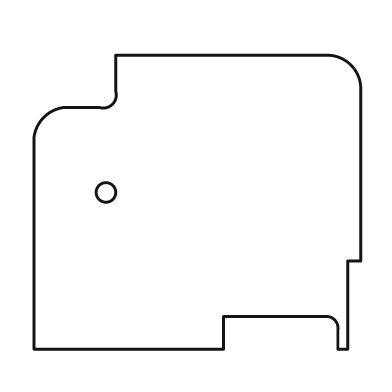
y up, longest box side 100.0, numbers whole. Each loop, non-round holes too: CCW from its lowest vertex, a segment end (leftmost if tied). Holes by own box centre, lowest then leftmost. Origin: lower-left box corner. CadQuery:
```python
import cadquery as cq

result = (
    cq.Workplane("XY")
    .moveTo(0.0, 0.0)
    .lineTo(58.0, 0.0)
    .lineTo(58.0, 10.0)
    .lineTo(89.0, 10.0)
    .threePointArc((92.0, 9.0), (93.0, 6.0))
    .lineTo(93.0, 0.0)
    .lineTo(96.0, 0.0)
    .lineTo(96.0, 27.0)
    .lineTo(100.0, 27.0)
    .lineTo(100.0, 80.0)
    .threePointArc((97.0, 87.0), (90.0, 90.0))
    .lineTo(25.0, 90.0)
    .lineTo(25.0, 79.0)
    .threePointArc((24.0, 75.0), (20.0, 74.0))
    .lineTo(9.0, 74.0)
    .threePointArc((3.0, 71.0), (0.0, 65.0))
    .close()
    .moveTo(22.0, 48.0)
    .circle(3.0)
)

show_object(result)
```